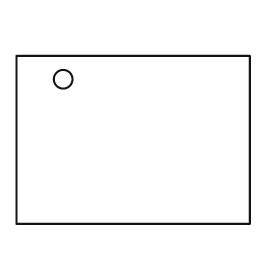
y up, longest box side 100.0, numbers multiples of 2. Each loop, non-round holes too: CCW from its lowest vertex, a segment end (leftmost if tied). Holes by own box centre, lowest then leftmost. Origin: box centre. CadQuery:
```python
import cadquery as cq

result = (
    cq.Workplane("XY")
    .moveTo(-50.0, -36.0)
    .lineTo(50.0, -36.0)
    .lineTo(50.0, 36.0)
    .lineTo(-50.0, 36.0)
    .close()
    .moveTo(-30.0, 26.0)
    .circle(4.0)
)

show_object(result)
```